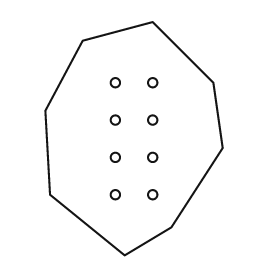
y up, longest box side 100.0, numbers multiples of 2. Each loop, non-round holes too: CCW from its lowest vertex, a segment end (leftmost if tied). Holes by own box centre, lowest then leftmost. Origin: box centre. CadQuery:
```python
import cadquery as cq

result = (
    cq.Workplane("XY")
    .moveTo(-4.0, -50.0)
    .lineTo(16.0, -38.0)
    .lineTo(38.0, -4.0)
    .lineTo(34.0, 24.0)
    .lineTo(8.0, 50.0)
    .lineTo(-22.0, 42.0)
    .lineTo(-38.0, 12.0)
    .lineTo(-36.0, -24.0)
    .close()
    .moveTo(-8.0, -24.0)
    .circle(2.0)
    .moveTo(8.0, -24.0)
    .circle(2.0)
    .moveTo(-8.0, -8.0)
    .circle(2.0)
    .moveTo(8.0, -8.0)
    .circle(2.0)
    .moveTo(-8.0, 8.0)
    .circle(2.0)
    .moveTo(8.0, 8.0)
    .circle(2.0)
    .moveTo(-8.0, 24.0)
    .circle(2.0)
    .moveTo(8.0, 24.0)
    .circle(2.0)
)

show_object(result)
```